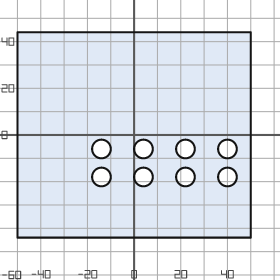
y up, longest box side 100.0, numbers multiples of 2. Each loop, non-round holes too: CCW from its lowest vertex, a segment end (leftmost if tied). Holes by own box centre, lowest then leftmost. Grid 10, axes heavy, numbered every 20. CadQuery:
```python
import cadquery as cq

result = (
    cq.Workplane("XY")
    .moveTo(-50.0, -44.0)
    .lineTo(50.0, -44.0)
    .lineTo(50.0, 44.0)
    .lineTo(-50.0, 44.0)
    .close()
    .moveTo(-14.0, -18.0)
    .circle(4.0)
    .moveTo(4.0, -18.0)
    .circle(4.0)
    .moveTo(22.0, -18.0)
    .circle(4.0)
    .moveTo(40.0, -18.0)
    .circle(4.0)
    .moveTo(-14.0, -6.0)
    .circle(4.0)
    .moveTo(4.0, -6.0)
    .circle(4.0)
    .moveTo(22.0, -6.0)
    .circle(4.0)
    .moveTo(40.0, -6.0)
    .circle(4.0)
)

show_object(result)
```